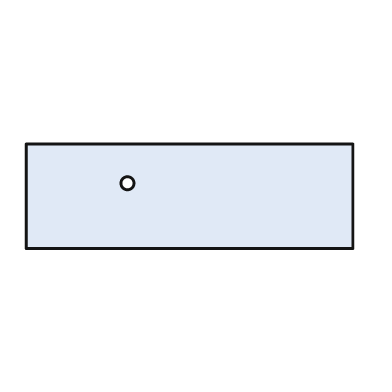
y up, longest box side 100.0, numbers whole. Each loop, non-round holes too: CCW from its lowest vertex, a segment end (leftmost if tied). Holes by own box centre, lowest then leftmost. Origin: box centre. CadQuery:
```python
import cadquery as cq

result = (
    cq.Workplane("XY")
    .moveTo(-50.0, -16.0)
    .lineTo(50.0, -16.0)
    .lineTo(50.0, 16.0)
    .lineTo(-50.0, 16.0)
    .close()
    .moveTo(-19.0, 4.0)
    .circle(2.0)
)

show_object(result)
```